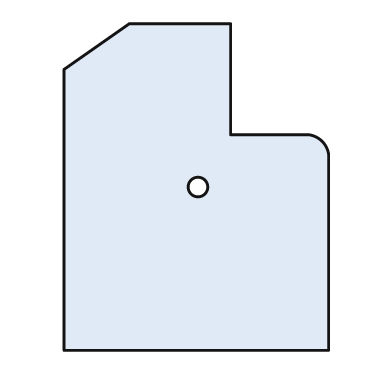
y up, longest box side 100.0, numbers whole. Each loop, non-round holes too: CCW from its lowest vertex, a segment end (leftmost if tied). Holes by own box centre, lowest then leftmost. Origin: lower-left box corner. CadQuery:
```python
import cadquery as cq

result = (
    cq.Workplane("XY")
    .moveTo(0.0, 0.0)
    .lineTo(81.0, 0.0)
    .lineTo(81.0, 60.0)
    .threePointArc((79.0, 64.0), (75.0, 66.0))
    .lineTo(51.0, 66.0)
    .lineTo(51.0, 100.0)
    .lineTo(20.0, 100.0)
    .lineTo(0.0, 86.0)
    .close()
    .moveTo(41.0, 50.0)
    .circle(3.0)
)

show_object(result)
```